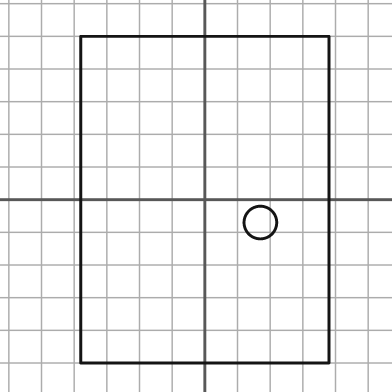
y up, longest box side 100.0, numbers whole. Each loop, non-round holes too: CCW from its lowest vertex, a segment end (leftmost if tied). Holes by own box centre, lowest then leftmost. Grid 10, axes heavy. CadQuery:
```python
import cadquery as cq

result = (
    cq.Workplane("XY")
    .moveTo(-38.0, -50.0)
    .lineTo(38.0, -50.0)
    .lineTo(38.0, 50.0)
    .lineTo(-38.0, 50.0)
    .close()
    .moveTo(17.0, -7.0)
    .circle(5.0)
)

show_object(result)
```